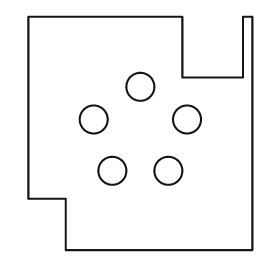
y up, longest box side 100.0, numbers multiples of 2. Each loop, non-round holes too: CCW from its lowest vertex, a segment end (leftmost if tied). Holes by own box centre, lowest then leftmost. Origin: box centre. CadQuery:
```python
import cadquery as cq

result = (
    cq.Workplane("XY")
    .moveTo(-32.0, -50.0)
    .lineTo(48.0, -50.0)
    .lineTo(48.0, 50.0)
    .lineTo(44.0, 50.0)
    .lineTo(44.0, 24.0)
    .lineTo(18.0, 24.0)
    .lineTo(18.0, 50.0)
    .lineTo(-48.0, 50.0)
    .lineTo(-48.0, -28.0)
    .lineTo(-32.0, -28.0)
    .close()
    .moveTo(-12.0, -16.0)
    .circle(6.0)
    .moveTo(12.0, -16.0)
    .circle(6.0)
    .moveTo(-20.0, 6.0)
    .circle(6.0)
    .moveTo(20.0, 6.0)
    .circle(6.0)
    .moveTo(0.0, 20.0)
    .circle(6.0)
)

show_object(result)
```